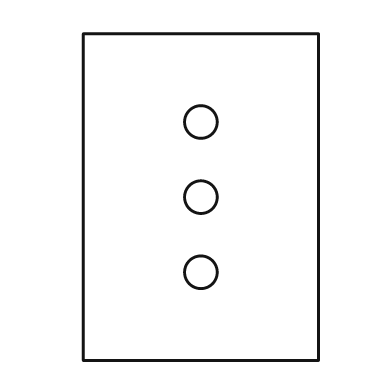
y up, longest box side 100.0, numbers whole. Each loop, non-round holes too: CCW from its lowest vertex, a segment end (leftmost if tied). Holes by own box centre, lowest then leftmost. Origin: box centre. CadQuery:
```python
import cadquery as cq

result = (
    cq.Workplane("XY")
    .moveTo(-36.0, -50.0)
    .lineTo(36.0, -50.0)
    .lineTo(36.0, 50.0)
    .lineTo(-36.0, 50.0)
    .close()
    .moveTo(0.0, -23.0)
    .circle(5.0)
    .moveTo(0.0, 0.0)
    .circle(5.0)
    .moveTo(0.0, 23.0)
    .circle(5.0)
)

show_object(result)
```